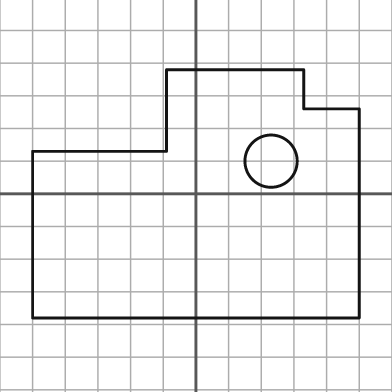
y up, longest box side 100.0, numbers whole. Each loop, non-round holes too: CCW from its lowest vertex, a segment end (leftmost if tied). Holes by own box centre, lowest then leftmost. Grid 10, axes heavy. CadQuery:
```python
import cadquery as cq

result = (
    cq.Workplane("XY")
    .moveTo(-50.0, -38.0)
    .lineTo(50.0, -38.0)
    .lineTo(50.0, 26.0)
    .lineTo(33.0, 26.0)
    .lineTo(33.0, 38.0)
    .lineTo(-9.0, 38.0)
    .lineTo(-9.0, 13.0)
    .lineTo(-50.0, 13.0)
    .close()
    .moveTo(23.0, 10.0)
    .circle(8.0)
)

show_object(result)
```